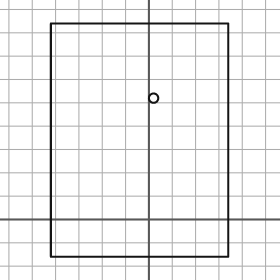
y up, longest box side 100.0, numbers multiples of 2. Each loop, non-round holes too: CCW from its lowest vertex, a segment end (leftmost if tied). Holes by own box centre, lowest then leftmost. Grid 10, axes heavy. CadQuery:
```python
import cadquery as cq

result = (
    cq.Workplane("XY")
    .moveTo(-42.0, -16.0)
    .lineTo(34.0, -16.0)
    .lineTo(34.0, 84.0)
    .lineTo(-42.0, 84.0)
    .close()
    .moveTo(2.0, 52.0)
    .circle(2.0)
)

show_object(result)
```